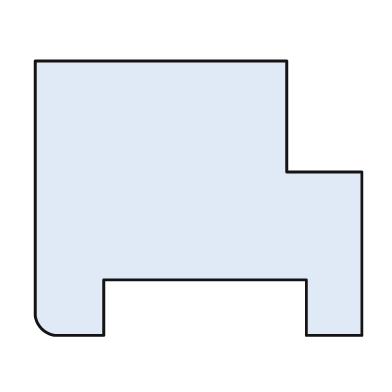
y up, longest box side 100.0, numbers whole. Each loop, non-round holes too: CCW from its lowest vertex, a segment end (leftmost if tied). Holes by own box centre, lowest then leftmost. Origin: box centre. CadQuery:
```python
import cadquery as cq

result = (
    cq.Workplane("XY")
    .moveTo(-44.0, -42.0)
    .lineTo(-29.0, -42.0)
    .lineTo(-29.0, -25.0)
    .lineTo(33.0, -25.0)
    .lineTo(33.0, -42.0)
    .lineTo(50.0, -42.0)
    .lineTo(50.0, 8.0)
    .lineTo(27.0, 8.0)
    .lineTo(27.0, 42.0)
    .lineTo(-50.0, 42.0)
    .lineTo(-50.0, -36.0)
    .threePointArc((-48.0, -40.0), (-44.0, -42.0))
    .close()
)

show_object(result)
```